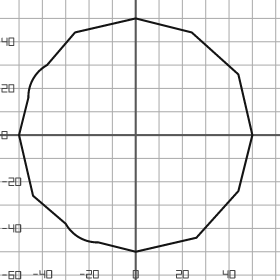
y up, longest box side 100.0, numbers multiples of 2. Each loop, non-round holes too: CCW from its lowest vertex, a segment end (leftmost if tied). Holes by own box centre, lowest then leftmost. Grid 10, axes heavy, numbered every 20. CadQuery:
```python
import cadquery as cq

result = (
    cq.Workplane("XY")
    .moveTo(0.0, -50.0)
    .lineTo(26.0, -44.0)
    .lineTo(44.0, -24.0)
    .lineTo(50.0, 0.0)
    .lineTo(44.0, 26.0)
    .lineTo(24.0, 44.0)
    .lineTo(0.0, 50.0)
    .lineTo(-26.0, 44.0)
    .lineTo(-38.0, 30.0)
    .threePointArc((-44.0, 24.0), (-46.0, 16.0))
    .lineTo(-50.0, 0.0)
    .lineTo(-44.0, -26.0)
    .lineTo(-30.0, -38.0)
    .threePointArc((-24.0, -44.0), (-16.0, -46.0))
    .close()
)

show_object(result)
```